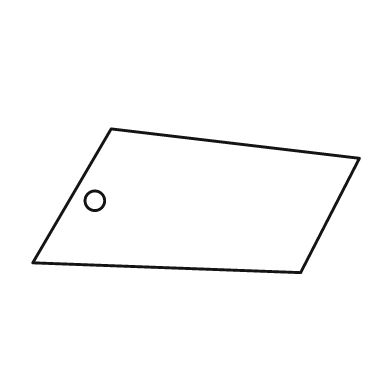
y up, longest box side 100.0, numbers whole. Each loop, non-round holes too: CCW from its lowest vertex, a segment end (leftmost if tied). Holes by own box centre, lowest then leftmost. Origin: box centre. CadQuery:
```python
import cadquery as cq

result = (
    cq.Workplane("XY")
    .moveTo(32.0, -22.0)
    .lineTo(50.0, 13.0)
    .lineTo(-26.0, 22.0)
    .lineTo(-50.0, -19.0)
    .close()
    .moveTo(-31.0, 0.0)
    .circle(3.0)
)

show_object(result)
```